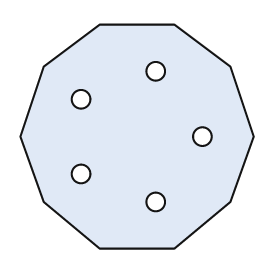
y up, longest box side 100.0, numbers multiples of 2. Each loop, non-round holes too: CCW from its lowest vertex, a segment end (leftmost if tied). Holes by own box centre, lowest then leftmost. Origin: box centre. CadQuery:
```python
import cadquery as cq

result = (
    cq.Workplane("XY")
    .moveTo(-16.0, -48.0)
    .lineTo(16.0, -48.0)
    .lineTo(40.0, -28.0)
    .lineTo(50.0, 0.0)
    .lineTo(40.0, 30.0)
    .lineTo(16.0, 48.0)
    .lineTo(-16.0, 48.0)
    .lineTo(-40.0, 30.0)
    .lineTo(-50.0, 0.0)
    .lineTo(-40.0, -28.0)
    .close()
    .moveTo(8.0, -28.0)
    .circle(4.0)
    .moveTo(-24.0, -16.0)
    .circle(4.0)
    .moveTo(28.0, 0.0)
    .circle(4.0)
    .moveTo(-24.0, 16.0)
    .circle(4.0)
    .moveTo(8.0, 28.0)
    .circle(4.0)
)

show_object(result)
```